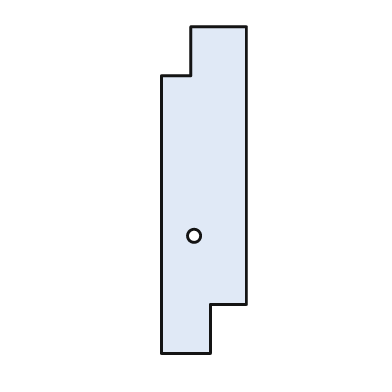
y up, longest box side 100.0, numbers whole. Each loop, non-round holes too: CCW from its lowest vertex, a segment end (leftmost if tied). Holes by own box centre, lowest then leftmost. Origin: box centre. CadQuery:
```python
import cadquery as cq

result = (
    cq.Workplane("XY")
    .moveTo(-13.0, -50.0)
    .lineTo(2.0, -50.0)
    .lineTo(2.0, -35.0)
    .lineTo(13.0, -35.0)
    .lineTo(13.0, 50.0)
    .lineTo(-4.0, 50.0)
    .lineTo(-4.0, 35.0)
    .lineTo(-13.0, 35.0)
    .close()
    .moveTo(-3.0, -14.0)
    .circle(2.0)
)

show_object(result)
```